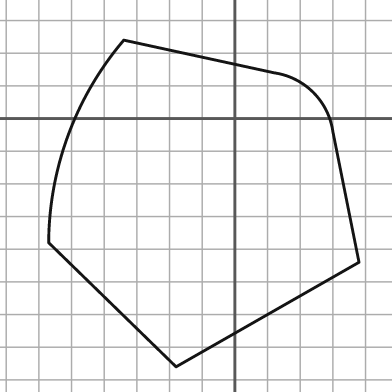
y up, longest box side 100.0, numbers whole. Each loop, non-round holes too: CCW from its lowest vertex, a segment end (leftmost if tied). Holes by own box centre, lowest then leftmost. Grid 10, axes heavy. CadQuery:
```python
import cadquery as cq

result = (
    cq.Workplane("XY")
    .moveTo(-18.0, -76.0)
    .lineTo(38.0, -44.0)
    .lineTo(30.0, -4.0)
    .threePointArc((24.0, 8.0), (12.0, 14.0))
    .lineTo(-34.0, 24.0)
    .threePointArc((-51.0, -5.0), (-57.0, -38.0))
    .close()
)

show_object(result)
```